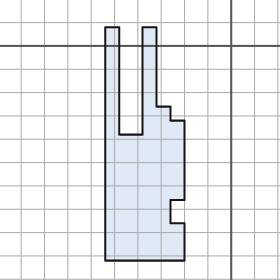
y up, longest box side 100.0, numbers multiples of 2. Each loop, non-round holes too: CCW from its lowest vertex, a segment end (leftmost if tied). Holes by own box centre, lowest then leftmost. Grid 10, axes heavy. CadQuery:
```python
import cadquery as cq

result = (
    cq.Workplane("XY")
    .moveTo(-54.0, -92.0)
    .lineTo(-20.0, -92.0)
    .lineTo(-20.0, -76.0)
    .lineTo(-26.0, -76.0)
    .lineTo(-26.0, -66.0)
    .lineTo(-20.0, -66.0)
    .lineTo(-20.0, -32.0)
    .lineTo(-26.0, -32.0)
    .lineTo(-26.0, -26.0)
    .lineTo(-32.0, -26.0)
    .lineTo(-32.0, 8.0)
    .lineTo(-38.0, 8.0)
    .lineTo(-38.0, -38.0)
    .lineTo(-48.0, -38.0)
    .lineTo(-48.0, 8.0)
    .lineTo(-54.0, 8.0)
    .close()
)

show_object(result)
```